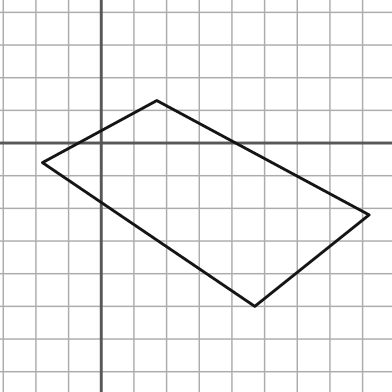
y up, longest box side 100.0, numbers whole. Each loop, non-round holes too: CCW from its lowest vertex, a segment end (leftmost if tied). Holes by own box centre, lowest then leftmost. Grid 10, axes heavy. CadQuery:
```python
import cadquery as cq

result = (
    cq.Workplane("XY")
    .moveTo(47.0, -50.0)
    .lineTo(82.0, -22.0)
    .lineTo(17.0, 13.0)
    .lineTo(-18.0, -6.0)
    .close()
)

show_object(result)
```